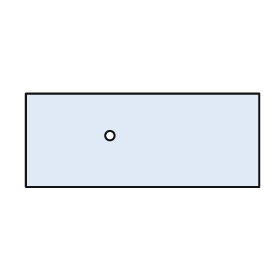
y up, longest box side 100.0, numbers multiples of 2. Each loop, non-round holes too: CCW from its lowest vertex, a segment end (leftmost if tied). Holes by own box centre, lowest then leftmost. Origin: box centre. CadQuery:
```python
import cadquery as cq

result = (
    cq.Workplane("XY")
    .moveTo(-50.0, -20.0)
    .lineTo(50.0, -20.0)
    .lineTo(50.0, 20.0)
    .lineTo(-50.0, 20.0)
    .close()
    .moveTo(-14.0, 2.0)
    .circle(2.0)
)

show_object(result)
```